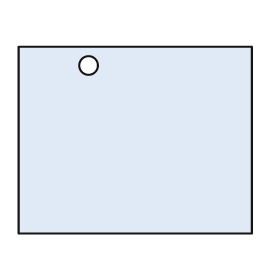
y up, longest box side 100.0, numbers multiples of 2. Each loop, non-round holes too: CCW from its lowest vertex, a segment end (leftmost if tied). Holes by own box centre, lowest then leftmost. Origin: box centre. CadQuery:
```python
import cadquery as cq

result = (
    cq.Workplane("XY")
    .moveTo(-50.0, -40.0)
    .lineTo(50.0, -40.0)
    .lineTo(50.0, 40.0)
    .lineTo(-50.0, 40.0)
    .close()
    .moveTo(-20.0, 32.0)
    .circle(4.0)
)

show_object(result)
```